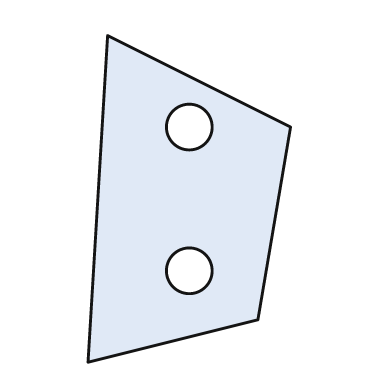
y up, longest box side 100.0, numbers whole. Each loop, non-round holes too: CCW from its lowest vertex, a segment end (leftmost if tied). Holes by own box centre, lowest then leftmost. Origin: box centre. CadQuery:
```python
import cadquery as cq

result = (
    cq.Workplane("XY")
    .moveTo(-31.0, -50.0)
    .lineTo(21.0, -37.0)
    .lineTo(31.0, 22.0)
    .lineTo(-25.0, 50.0)
    .close()
    .moveTo(0.0, -22.0)
    .circle(7.0)
    .moveTo(0.0, 22.0)
    .circle(7.0)
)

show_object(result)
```